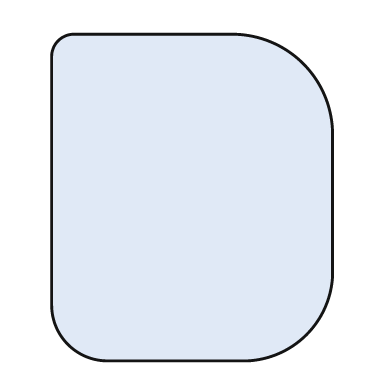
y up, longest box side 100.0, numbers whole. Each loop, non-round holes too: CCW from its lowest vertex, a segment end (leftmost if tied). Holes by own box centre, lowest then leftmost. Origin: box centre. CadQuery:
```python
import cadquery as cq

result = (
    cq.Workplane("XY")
    .moveTo(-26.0, -50.0)
    .lineTo(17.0, -50.0)
    .threePointArc((35.0, -42.0), (43.0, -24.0))
    .lineTo(43.0, 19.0)
    .threePointArc((34.0, 41.0), (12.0, 50.0))
    .lineTo(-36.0, 50.0)
    .threePointArc((-41.0, 48.0), (-43.0, 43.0))
    .lineTo(-43.0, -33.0)
    .threePointArc((-38.0, -45.0), (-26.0, -50.0))
    .close()
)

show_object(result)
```